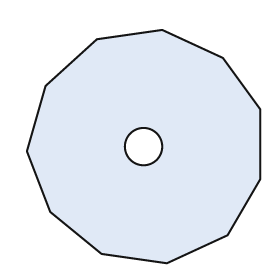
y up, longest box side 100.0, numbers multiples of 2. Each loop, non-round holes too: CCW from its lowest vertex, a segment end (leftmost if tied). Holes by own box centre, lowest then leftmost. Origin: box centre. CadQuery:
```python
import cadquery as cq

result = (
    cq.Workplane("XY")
    .moveTo(10.0, -50.0)
    .lineTo(36.0, -38.0)
    .lineTo(50.0, -14.0)
    .lineTo(50.0, 16.0)
    .lineTo(34.0, 38.0)
    .lineTo(8.0, 50.0)
    .lineTo(-20.0, 46.0)
    .lineTo(-42.0, 26.0)
    .lineTo(-50.0, -2.0)
    .lineTo(-40.0, -28.0)
    .lineTo(-18.0, -46.0)
    .close()
    .moveTo(0.0, 0.0)
    .circle(8.0)
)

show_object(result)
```